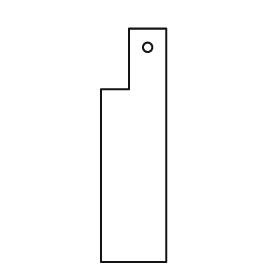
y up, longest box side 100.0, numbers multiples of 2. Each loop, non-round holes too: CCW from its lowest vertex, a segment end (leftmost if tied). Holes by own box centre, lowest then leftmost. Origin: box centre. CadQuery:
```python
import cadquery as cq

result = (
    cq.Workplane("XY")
    .moveTo(-14.0, -50.0)
    .lineTo(14.0, -50.0)
    .lineTo(14.0, 50.0)
    .lineTo(-2.0, 50.0)
    .lineTo(-2.0, 24.0)
    .lineTo(-14.0, 24.0)
    .close()
    .moveTo(6.0, 42.0)
    .circle(2.0)
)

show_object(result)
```